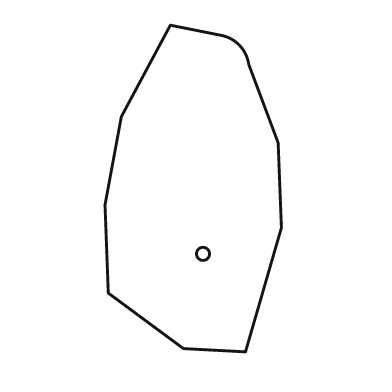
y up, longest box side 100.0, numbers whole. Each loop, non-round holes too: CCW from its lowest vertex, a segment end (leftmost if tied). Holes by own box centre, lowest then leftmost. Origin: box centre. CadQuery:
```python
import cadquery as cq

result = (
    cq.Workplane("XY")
    .moveTo(16.0, -50.0)
    .lineTo(27.0, -12.0)
    .lineTo(26.0, 14.0)
    .lineTo(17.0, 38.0)
    .threePointArc((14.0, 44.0), (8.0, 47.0))
    .lineTo(-7.0, 50.0)
    .lineTo(-22.0, 22.0)
    .lineTo(-27.0, -5.0)
    .lineTo(-26.0, -32.0)
    .lineTo(-3.0, -49.0)
    .close()
    .moveTo(3.0, -20.0)
    .circle(2.0)
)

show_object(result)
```